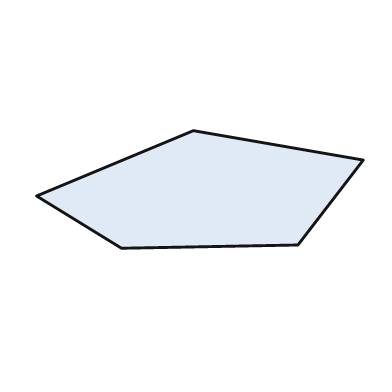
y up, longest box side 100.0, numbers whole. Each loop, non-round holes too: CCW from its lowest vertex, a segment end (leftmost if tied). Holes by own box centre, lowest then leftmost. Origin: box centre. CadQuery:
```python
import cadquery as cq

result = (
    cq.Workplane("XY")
    .moveTo(-24.0, -18.0)
    .lineTo(30.0, -17.0)
    .lineTo(50.0, 9.0)
    .lineTo(-2.0, 18.0)
    .lineTo(-50.0, -2.0)
    .close()
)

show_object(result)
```